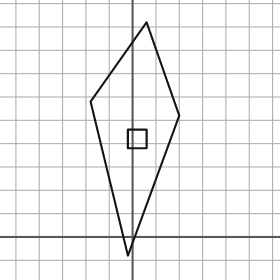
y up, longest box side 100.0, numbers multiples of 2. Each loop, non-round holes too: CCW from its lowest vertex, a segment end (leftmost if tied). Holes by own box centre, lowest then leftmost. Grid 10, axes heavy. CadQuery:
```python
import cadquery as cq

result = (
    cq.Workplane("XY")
    .moveTo(-2.0, -8.0)
    .lineTo(20.0, 52.0)
    .lineTo(6.0, 92.0)
    .lineTo(-18.0, 58.0)
    .close()
    .moveTo(-2.0, 38.0)
    .lineTo(6.0, 38.0)
    .lineTo(6.0, 46.0)
    .lineTo(-2.0, 46.0)
    .close()
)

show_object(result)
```